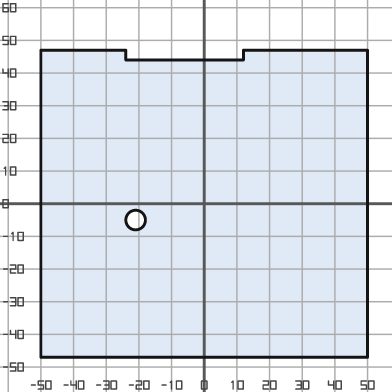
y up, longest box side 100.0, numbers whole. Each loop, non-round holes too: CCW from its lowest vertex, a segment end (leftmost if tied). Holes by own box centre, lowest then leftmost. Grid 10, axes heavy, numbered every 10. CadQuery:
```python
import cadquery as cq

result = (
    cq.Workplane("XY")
    .moveTo(-50.0, -47.0)
    .lineTo(50.0, -47.0)
    .lineTo(50.0, 47.0)
    .lineTo(12.0, 47.0)
    .lineTo(12.0, 44.0)
    .lineTo(-24.0, 44.0)
    .lineTo(-24.0, 47.0)
    .lineTo(-50.0, 47.0)
    .close()
    .moveTo(-21.0, -5.0)
    .circle(3.0)
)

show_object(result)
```